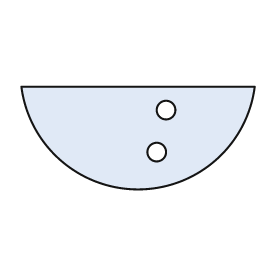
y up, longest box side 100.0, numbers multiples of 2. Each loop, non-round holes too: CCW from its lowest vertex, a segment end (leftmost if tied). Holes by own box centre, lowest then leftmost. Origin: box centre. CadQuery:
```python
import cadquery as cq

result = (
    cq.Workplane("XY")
    .moveTo(-50.0, 22.0)
    .threePointArc((0.0, -22.0), (50.0, 22.0))
    .close()
    .moveTo(8.0, -6.0)
    .circle(4.0)
    .moveTo(12.0, 12.0)
    .circle(4.0)
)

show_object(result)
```